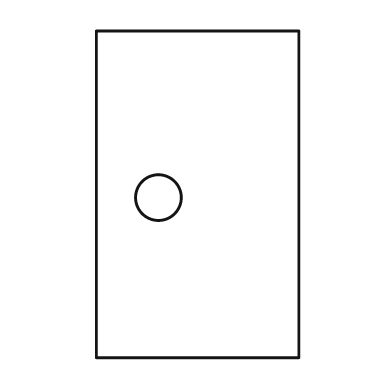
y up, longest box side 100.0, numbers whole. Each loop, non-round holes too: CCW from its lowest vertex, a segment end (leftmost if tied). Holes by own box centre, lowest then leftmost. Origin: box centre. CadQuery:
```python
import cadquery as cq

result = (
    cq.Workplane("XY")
    .moveTo(-31.0, -50.0)
    .lineTo(31.0, -50.0)
    .lineTo(31.0, 50.0)
    .lineTo(-31.0, 50.0)
    .close()
    .moveTo(-12.0, -1.0)
    .circle(7.0)
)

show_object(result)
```